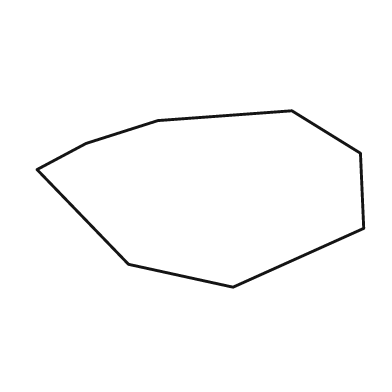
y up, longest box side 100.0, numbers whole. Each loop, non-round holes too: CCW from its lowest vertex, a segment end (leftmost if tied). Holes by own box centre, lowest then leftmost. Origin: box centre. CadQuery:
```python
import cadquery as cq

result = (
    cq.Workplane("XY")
    .moveTo(10.0, -27.0)
    .lineTo(50.0, -9.0)
    .lineTo(49.0, 14.0)
    .lineTo(28.0, 27.0)
    .lineTo(-13.0, 24.0)
    .lineTo(-35.0, 17.0)
    .lineTo(-50.0, 9.0)
    .lineTo(-22.0, -20.0)
    .close()
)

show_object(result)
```